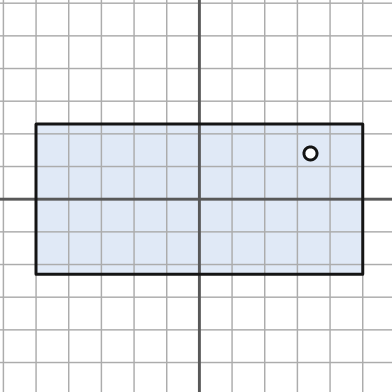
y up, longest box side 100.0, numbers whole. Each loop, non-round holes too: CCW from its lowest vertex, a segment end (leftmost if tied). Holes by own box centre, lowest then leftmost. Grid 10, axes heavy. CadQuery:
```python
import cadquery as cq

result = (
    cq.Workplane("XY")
    .moveTo(-50.0, -23.0)
    .lineTo(50.0, -23.0)
    .lineTo(50.0, 23.0)
    .lineTo(-50.0, 23.0)
    .close()
    .moveTo(34.0, 14.0)
    .circle(2.0)
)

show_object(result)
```